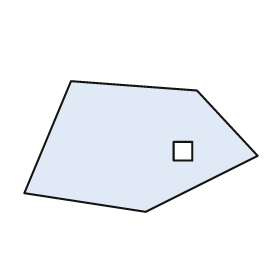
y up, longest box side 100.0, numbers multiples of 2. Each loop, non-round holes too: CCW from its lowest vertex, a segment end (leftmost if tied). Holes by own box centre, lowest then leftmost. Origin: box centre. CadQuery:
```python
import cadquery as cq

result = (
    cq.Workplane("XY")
    .moveTo(2.0, -28.0)
    .lineTo(50.0, -4.0)
    .lineTo(24.0, 24.0)
    .lineTo(-30.0, 28.0)
    .lineTo(-50.0, -20.0)
    .close()
    .moveTo(14.0, -6.0)
    .lineTo(22.0, -6.0)
    .lineTo(22.0, 2.0)
    .lineTo(14.0, 2.0)
    .close()
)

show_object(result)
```